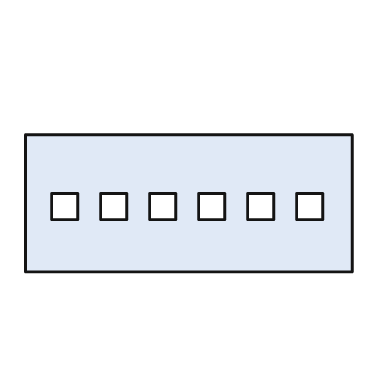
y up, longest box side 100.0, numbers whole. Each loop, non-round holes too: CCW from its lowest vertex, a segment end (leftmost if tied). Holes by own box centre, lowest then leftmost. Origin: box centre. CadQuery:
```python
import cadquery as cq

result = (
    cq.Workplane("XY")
    .moveTo(-50.0, -21.0)
    .lineTo(50.0, -21.0)
    .lineTo(50.0, 21.0)
    .lineTo(-50.0, 21.0)
    .close()
    .moveTo(-42.0, -5.0)
    .lineTo(-34.0, -5.0)
    .lineTo(-34.0, 3.0)
    .lineTo(-42.0, 3.0)
    .close()
    .moveTo(-27.0, -5.0)
    .lineTo(-19.0, -5.0)
    .lineTo(-19.0, 3.0)
    .lineTo(-27.0, 3.0)
    .close()
    .moveTo(-12.0, -5.0)
    .lineTo(-4.0, -5.0)
    .lineTo(-4.0, 3.0)
    .lineTo(-12.0, 3.0)
    .close()
    .moveTo(3.0, -5.0)
    .lineTo(11.0, -5.0)
    .lineTo(11.0, 3.0)
    .lineTo(3.0, 3.0)
    .close()
    .moveTo(18.0, -5.0)
    .lineTo(26.0, -5.0)
    .lineTo(26.0, 3.0)
    .lineTo(18.0, 3.0)
    .close()
    .moveTo(33.0, -5.0)
    .lineTo(41.0, -5.0)
    .lineTo(41.0, 3.0)
    .lineTo(33.0, 3.0)
    .close()
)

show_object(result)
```